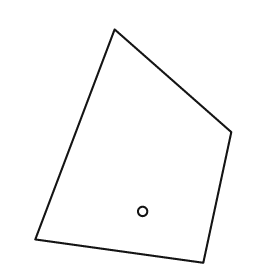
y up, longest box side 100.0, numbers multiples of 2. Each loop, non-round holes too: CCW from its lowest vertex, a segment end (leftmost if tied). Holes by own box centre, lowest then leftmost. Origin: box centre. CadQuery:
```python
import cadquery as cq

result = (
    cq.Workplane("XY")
    .moveTo(30.0, -50.0)
    .lineTo(42.0, 6.0)
    .lineTo(-8.0, 50.0)
    .lineTo(-42.0, -40.0)
    .close()
    .moveTo(4.0, -28.0)
    .circle(2.0)
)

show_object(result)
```